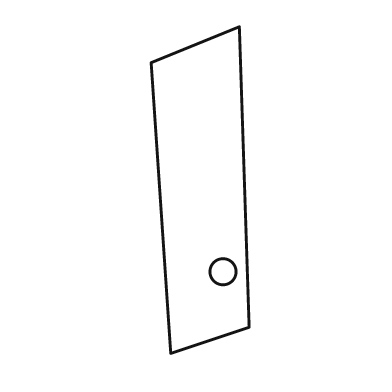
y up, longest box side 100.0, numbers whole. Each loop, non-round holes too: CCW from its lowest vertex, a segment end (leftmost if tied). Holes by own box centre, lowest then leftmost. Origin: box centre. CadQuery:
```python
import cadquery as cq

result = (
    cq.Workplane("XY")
    .moveTo(-9.0, -50.0)
    .lineTo(15.0, -42.0)
    .lineTo(12.0, 50.0)
    .lineTo(-15.0, 39.0)
    .close()
    .moveTo(7.0, -25.0)
    .circle(4.0)
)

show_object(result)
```